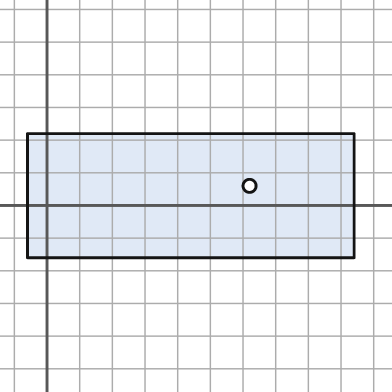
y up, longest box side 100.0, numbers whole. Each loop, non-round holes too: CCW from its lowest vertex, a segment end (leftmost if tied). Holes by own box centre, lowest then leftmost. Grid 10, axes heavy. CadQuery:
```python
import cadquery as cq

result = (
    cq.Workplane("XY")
    .moveTo(-6.0, -16.0)
    .lineTo(94.0, -16.0)
    .lineTo(94.0, 22.0)
    .lineTo(-6.0, 22.0)
    .close()
    .moveTo(62.0, 6.0)
    .circle(2.0)
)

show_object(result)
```